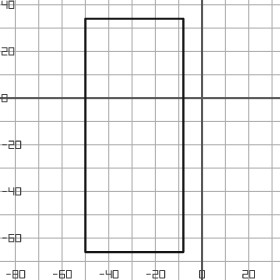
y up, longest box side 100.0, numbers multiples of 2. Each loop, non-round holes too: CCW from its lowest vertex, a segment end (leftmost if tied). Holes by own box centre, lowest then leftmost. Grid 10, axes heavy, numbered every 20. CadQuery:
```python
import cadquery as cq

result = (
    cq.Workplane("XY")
    .moveTo(-50.0, -66.0)
    .lineTo(-8.0, -66.0)
    .lineTo(-8.0, 34.0)
    .lineTo(-50.0, 34.0)
    .close()
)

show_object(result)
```